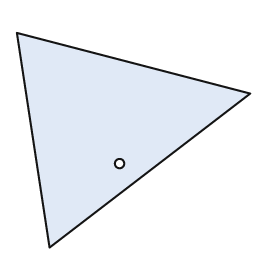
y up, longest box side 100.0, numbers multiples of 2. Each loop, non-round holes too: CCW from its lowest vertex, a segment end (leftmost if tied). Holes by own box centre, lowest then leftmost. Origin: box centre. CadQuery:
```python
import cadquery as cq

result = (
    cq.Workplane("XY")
    .moveTo(-36.0, -46.0)
    .lineTo(50.0, 20.0)
    .lineTo(-50.0, 46.0)
    .close()
    .moveTo(-6.0, -10.0)
    .circle(2.0)
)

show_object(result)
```